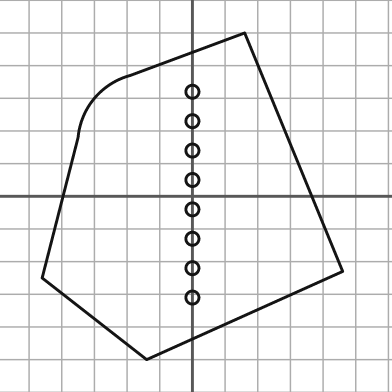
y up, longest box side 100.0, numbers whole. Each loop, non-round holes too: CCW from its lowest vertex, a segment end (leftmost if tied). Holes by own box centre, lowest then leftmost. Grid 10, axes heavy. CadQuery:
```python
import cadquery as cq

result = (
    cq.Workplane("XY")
    .moveTo(-14.0, -50.0)
    .lineTo(46.0, -23.0)
    .lineTo(16.0, 50.0)
    .lineTo(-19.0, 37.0)
    .threePointArc((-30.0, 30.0), (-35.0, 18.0))
    .lineTo(-46.0, -25.0)
    .close()
    .moveTo(0.0, -31.0)
    .circle(2.0)
    .moveTo(0.0, -22.0)
    .circle(2.0)
    .moveTo(0.0, -13.0)
    .circle(2.0)
    .moveTo(0.0, -4.0)
    .circle(2.0)
    .moveTo(0.0, 5.0)
    .circle(2.0)
    .moveTo(0.0, 14.0)
    .circle(2.0)
    .moveTo(0.0, 23.0)
    .circle(2.0)
    .moveTo(0.0, 32.0)
    .circle(2.0)
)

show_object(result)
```